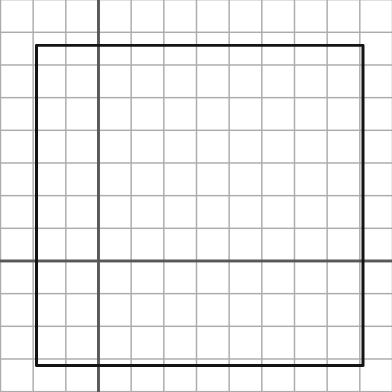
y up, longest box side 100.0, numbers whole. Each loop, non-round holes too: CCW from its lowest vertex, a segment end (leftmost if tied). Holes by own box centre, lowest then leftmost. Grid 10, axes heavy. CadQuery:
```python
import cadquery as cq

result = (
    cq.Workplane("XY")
    .moveTo(-19.0, -32.0)
    .lineTo(81.0, -32.0)
    .lineTo(81.0, 66.0)
    .lineTo(-19.0, 66.0)
    .close()
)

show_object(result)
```